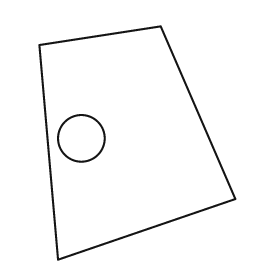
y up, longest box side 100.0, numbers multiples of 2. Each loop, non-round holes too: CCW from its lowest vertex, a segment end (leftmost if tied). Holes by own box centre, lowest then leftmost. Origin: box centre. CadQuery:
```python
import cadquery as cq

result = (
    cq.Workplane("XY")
    .moveTo(-34.0, -50.0)
    .lineTo(42.0, -24.0)
    .lineTo(10.0, 50.0)
    .lineTo(-42.0, 42.0)
    .close()
    .moveTo(-24.0, 2.0)
    .circle(10.0)
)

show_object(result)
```